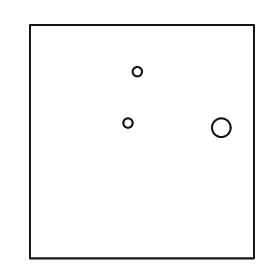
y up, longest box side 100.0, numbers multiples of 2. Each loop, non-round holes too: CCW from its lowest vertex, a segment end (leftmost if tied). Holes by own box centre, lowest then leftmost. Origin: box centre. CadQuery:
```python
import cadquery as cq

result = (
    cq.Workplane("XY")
    .moveTo(-48.0, -50.0)
    .lineTo(48.0, -50.0)
    .lineTo(48.0, 50.0)
    .lineTo(-48.0, 50.0)
    .close()
    .moveTo(34.0, 6.0)
    .circle(4.0)
    .moveTo(-6.0, 8.0)
    .circle(2.0)
    .moveTo(-2.0, 30.0)
    .circle(2.0)
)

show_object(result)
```